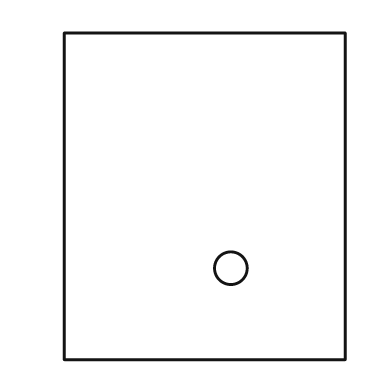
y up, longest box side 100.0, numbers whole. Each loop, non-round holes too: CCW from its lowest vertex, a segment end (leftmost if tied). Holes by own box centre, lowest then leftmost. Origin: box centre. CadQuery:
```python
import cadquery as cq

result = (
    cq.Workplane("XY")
    .moveTo(-43.0, -50.0)
    .lineTo(43.0, -50.0)
    .lineTo(43.0, 50.0)
    .lineTo(-43.0, 50.0)
    .close()
    .moveTo(8.0, -22.0)
    .circle(5.0)
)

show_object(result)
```